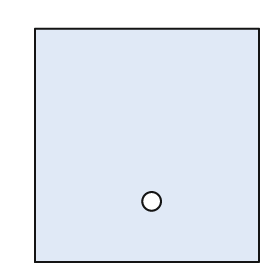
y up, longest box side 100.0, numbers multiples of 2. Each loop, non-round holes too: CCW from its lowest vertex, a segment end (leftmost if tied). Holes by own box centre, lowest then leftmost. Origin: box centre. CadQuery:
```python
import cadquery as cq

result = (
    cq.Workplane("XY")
    .moveTo(-48.0, -50.0)
    .lineTo(48.0, -50.0)
    .lineTo(48.0, 50.0)
    .lineTo(-48.0, 50.0)
    .close()
    .moveTo(2.0, -24.0)
    .circle(4.0)
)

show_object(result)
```